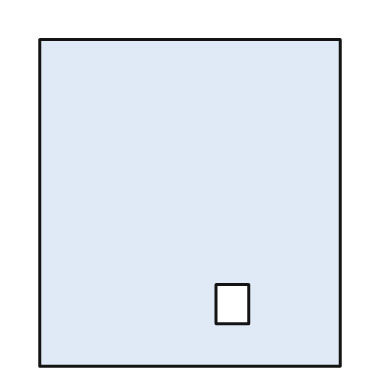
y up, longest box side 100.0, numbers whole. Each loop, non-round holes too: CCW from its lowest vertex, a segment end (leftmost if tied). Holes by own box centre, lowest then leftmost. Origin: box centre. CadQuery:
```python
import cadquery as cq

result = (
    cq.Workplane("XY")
    .moveTo(-46.0, -50.0)
    .lineTo(46.0, -50.0)
    .lineTo(46.0, 50.0)
    .lineTo(-46.0, 50.0)
    .close()
    .moveTo(8.0, -37.0)
    .lineTo(18.0, -37.0)
    .lineTo(18.0, -25.0)
    .lineTo(8.0, -25.0)
    .close()
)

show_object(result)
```